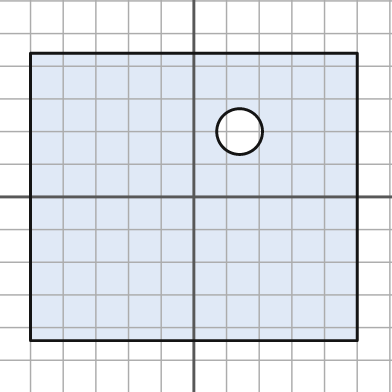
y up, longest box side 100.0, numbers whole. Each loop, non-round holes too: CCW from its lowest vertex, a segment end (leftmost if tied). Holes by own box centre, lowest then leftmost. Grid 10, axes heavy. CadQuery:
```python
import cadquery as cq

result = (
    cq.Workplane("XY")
    .moveTo(-50.0, -44.0)
    .lineTo(50.0, -44.0)
    .lineTo(50.0, 44.0)
    .lineTo(-50.0, 44.0)
    .close()
    .moveTo(14.0, 20.0)
    .circle(7.0)
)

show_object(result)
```